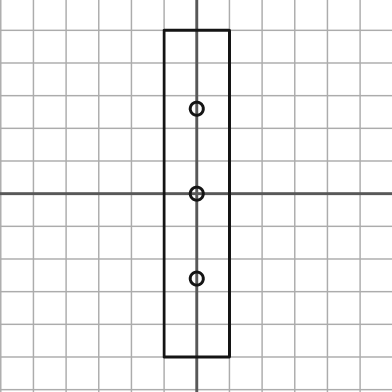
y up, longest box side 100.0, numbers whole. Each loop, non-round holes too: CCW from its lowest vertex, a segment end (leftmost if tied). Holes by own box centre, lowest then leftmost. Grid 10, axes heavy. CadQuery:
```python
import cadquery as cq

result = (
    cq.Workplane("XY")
    .moveTo(-10.0, -50.0)
    .lineTo(10.0, -50.0)
    .lineTo(10.0, 50.0)
    .lineTo(-10.0, 50.0)
    .close()
    .moveTo(0.0, -26.0)
    .circle(2.0)
    .moveTo(0.0, 0.0)
    .circle(2.0)
    .moveTo(0.0, 26.0)
    .circle(2.0)
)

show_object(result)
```